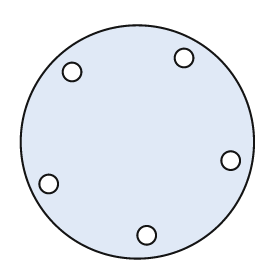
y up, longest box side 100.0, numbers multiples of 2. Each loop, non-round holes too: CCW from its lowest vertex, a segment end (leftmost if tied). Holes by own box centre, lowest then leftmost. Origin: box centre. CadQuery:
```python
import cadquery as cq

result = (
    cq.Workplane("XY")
    .moveTo(0.0, 0.0)
    .circle(50.0)
    .moveTo(4.0, -40.0)
    .circle(4.0)
    .moveTo(-38.0, -18.0)
    .circle(4.0)
    .moveTo(40.0, -8.0)
    .circle(4.0)
    .moveTo(-28.0, 30.0)
    .circle(4.0)
    .moveTo(20.0, 36.0)
    .circle(4.0)
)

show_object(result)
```